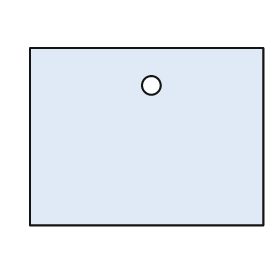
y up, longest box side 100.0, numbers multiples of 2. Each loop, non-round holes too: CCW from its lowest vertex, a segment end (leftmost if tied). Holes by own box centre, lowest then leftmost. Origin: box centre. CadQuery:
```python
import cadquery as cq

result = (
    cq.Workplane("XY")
    .moveTo(-50.0, -38.0)
    .lineTo(50.0, -38.0)
    .lineTo(50.0, 38.0)
    .lineTo(-50.0, 38.0)
    .close()
    .moveTo(2.0, 22.0)
    .circle(4.0)
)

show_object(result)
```